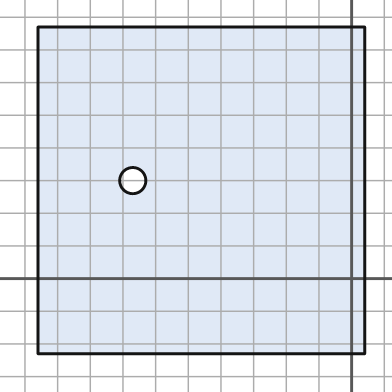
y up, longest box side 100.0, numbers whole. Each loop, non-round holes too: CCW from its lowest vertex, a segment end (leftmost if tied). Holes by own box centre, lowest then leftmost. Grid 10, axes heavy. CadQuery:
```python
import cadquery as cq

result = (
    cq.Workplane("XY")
    .moveTo(-96.0, -23.0)
    .lineTo(4.0, -23.0)
    .lineTo(4.0, 77.0)
    .lineTo(-96.0, 77.0)
    .close()
    .moveTo(-67.0, 30.0)
    .circle(4.0)
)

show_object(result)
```